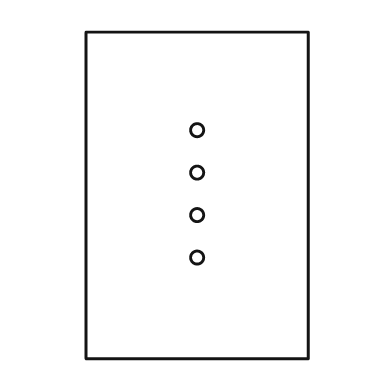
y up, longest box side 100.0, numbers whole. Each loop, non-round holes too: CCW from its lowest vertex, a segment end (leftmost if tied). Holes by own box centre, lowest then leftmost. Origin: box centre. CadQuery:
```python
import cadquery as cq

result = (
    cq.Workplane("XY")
    .moveTo(-34.0, -50.0)
    .lineTo(34.0, -50.0)
    .lineTo(34.0, 50.0)
    .lineTo(-34.0, 50.0)
    .close()
    .moveTo(0.0, -19.0)
    .circle(2.0)
    .moveTo(0.0, -6.0)
    .circle(2.0)
    .moveTo(0.0, 7.0)
    .circle(2.0)
    .moveTo(0.0, 20.0)
    .circle(2.0)
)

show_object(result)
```